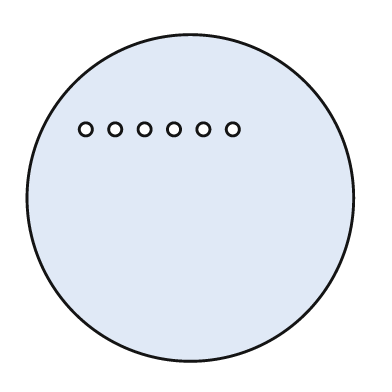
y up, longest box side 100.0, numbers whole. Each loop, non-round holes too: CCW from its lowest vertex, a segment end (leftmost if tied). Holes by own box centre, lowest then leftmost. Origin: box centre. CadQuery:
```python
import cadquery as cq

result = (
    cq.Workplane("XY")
    .moveTo(0.0, 0.0)
    .circle(50.0)
    .moveTo(-32.0, 21.0)
    .circle(2.0)
    .moveTo(-23.0, 21.0)
    .circle(2.0)
    .moveTo(-14.0, 21.0)
    .circle(2.0)
    .moveTo(-5.0, 21.0)
    .circle(2.0)
    .moveTo(4.0, 21.0)
    .circle(2.0)
    .moveTo(13.0, 21.0)
    .circle(2.0)
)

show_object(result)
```